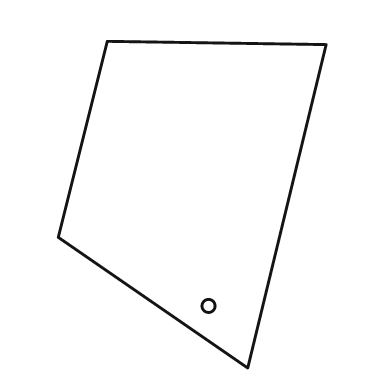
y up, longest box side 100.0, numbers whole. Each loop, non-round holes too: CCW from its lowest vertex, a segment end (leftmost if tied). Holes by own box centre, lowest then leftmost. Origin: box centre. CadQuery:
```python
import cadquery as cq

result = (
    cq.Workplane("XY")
    .moveTo(17.0, -50.0)
    .lineTo(41.0, 49.0)
    .lineTo(-26.0, 50.0)
    .lineTo(-41.0, -10.0)
    .close()
    .moveTo(5.0, -31.0)
    .circle(2.0)
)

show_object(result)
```